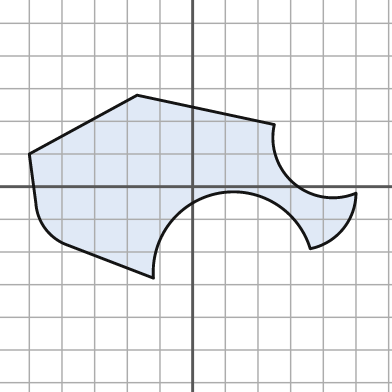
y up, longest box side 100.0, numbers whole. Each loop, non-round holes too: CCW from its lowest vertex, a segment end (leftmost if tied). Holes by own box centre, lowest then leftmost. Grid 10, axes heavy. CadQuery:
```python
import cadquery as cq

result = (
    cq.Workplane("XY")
    .moveTo(-12.0, -28.0)
    .threePointArc((8.0, -2.0), (36.0, -19.0))
    .threePointArc((46.0, -13.0), (50.0, -2.0))
    .threePointArc((31.0, 1.0), (25.0, 19.0))
    .lineTo(-17.0, 28.0)
    .lineTo(-50.0, 10.0)
    .lineTo(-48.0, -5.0)
    .threePointArc((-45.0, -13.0), (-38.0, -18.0))
    .close()
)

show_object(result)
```